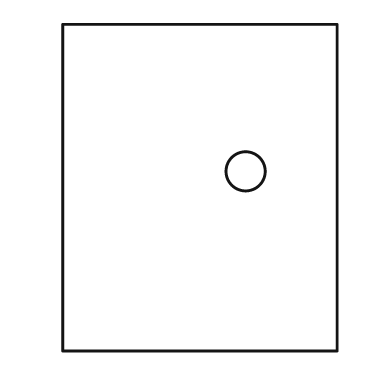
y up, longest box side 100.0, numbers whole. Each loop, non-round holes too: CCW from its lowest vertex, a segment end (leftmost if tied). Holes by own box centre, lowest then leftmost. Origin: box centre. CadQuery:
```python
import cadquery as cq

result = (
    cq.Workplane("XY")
    .moveTo(-42.0, -50.0)
    .lineTo(42.0, -50.0)
    .lineTo(42.0, 50.0)
    .lineTo(-42.0, 50.0)
    .close()
    .moveTo(14.0, 5.0)
    .circle(6.0)
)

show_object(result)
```